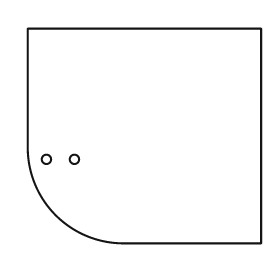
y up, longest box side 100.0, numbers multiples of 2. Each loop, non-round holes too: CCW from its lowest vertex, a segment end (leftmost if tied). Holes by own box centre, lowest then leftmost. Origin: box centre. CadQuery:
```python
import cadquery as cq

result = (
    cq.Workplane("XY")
    .moveTo(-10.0, -46.0)
    .lineTo(50.0, -46.0)
    .lineTo(50.0, 46.0)
    .lineTo(-50.0, 46.0)
    .lineTo(-50.0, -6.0)
    .threePointArc((-38.0, -34.0), (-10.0, -46.0))
    .close()
    .moveTo(-42.0, -10.0)
    .circle(2.0)
    .moveTo(-30.0, -10.0)
    .circle(2.0)
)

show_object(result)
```